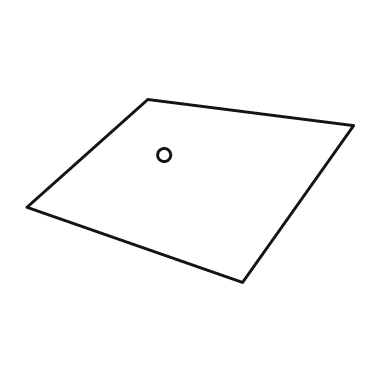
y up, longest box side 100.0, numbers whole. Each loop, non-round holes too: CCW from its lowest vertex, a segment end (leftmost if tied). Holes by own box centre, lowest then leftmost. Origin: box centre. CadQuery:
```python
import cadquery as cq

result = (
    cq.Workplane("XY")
    .moveTo(16.0, -28.0)
    .lineTo(50.0, 20.0)
    .lineTo(-13.0, 28.0)
    .lineTo(-50.0, -5.0)
    .close()
    .moveTo(-8.0, 11.0)
    .circle(2.0)
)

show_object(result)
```